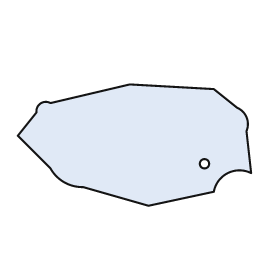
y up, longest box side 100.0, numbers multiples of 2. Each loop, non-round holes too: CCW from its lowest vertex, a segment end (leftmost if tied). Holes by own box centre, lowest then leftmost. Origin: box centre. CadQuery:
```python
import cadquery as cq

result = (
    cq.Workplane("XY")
    .moveTo(6.0, -26.0)
    .lineTo(34.0, -20.0)
    .threePointArc((40.0, -12.0), (50.0, -12.0))
    .lineTo(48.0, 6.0)
    .threePointArc((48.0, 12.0), (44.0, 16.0))
    .lineTo(34.0, 24.0)
    .lineTo(-2.0, 26.0)
    .lineTo(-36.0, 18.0)
    .threePointArc((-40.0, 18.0), (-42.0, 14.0))
    .lineTo(-50.0, 4.0)
    .lineTo(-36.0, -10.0)
    .threePointArc((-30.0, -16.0), (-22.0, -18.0))
    .close()
    .moveTo(30.0, -8.0)
    .circle(2.0)
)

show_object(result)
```